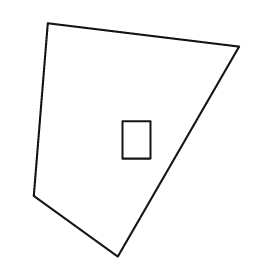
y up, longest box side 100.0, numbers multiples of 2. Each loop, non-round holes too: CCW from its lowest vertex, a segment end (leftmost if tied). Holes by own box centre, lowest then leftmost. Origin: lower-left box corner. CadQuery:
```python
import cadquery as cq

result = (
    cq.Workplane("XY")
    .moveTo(36.0, 0.0)
    .lineTo(88.0, 90.0)
    .lineTo(6.0, 100.0)
    .lineTo(0.0, 26.0)
    .close()
    .moveTo(38.0, 42.0)
    .lineTo(50.0, 42.0)
    .lineTo(50.0, 58.0)
    .lineTo(38.0, 58.0)
    .close()
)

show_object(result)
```